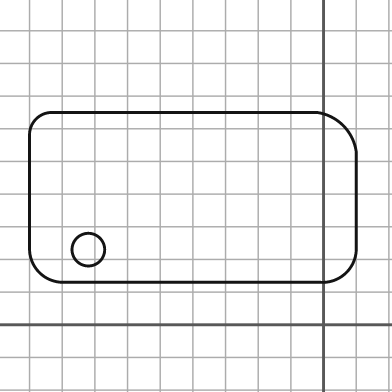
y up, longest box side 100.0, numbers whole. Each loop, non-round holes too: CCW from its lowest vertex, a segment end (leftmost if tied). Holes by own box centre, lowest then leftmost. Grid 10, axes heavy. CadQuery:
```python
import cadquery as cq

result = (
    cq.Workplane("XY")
    .moveTo(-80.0, 13.0)
    .lineTo(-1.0, 13.0)
    .threePointArc((7.0, 16.0), (10.0, 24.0))
    .lineTo(10.0, 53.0)
    .threePointArc((6.0, 61.0), (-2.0, 65.0))
    .lineTo(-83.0, 65.0)
    .threePointArc((-88.0, 63.0), (-90.0, 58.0))
    .lineTo(-90.0, 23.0)
    .threePointArc((-87.0, 16.0), (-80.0, 13.0))
    .close()
    .moveTo(-72.0, 23.0)
    .circle(5.0)
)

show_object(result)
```